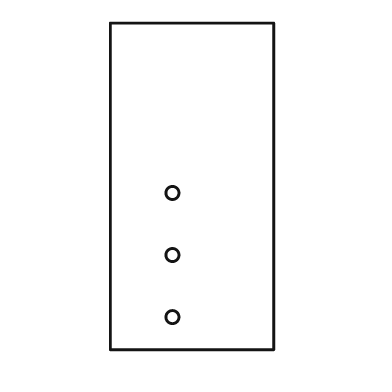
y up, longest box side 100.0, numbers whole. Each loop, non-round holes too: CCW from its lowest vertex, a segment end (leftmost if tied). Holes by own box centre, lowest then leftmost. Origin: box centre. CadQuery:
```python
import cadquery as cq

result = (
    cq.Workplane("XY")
    .moveTo(-25.0, -50.0)
    .lineTo(25.0, -50.0)
    .lineTo(25.0, 50.0)
    .lineTo(-25.0, 50.0)
    .close()
    .moveTo(-6.0, -40.0)
    .circle(2.0)
    .moveTo(-6.0, -21.0)
    .circle(2.0)
    .moveTo(-6.0, -2.0)
    .circle(2.0)
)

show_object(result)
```